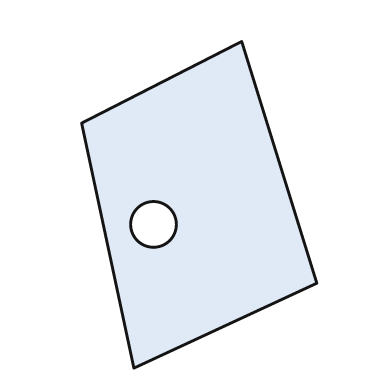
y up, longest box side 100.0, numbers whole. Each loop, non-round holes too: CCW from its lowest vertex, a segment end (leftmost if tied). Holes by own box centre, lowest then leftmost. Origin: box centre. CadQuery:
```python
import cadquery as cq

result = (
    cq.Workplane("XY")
    .moveTo(-20.0, -50.0)
    .lineTo(36.0, -24.0)
    .lineTo(13.0, 50.0)
    .lineTo(-36.0, 25.0)
    .close()
    .moveTo(-14.0, -6.0)
    .circle(7.0)
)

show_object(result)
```